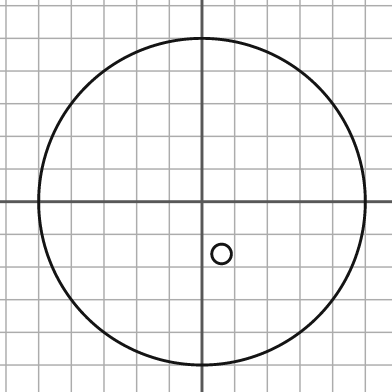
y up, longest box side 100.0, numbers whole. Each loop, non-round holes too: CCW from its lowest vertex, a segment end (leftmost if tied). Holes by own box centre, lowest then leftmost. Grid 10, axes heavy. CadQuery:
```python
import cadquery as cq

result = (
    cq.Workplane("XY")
    .moveTo(0.0, 0.0)
    .circle(50.0)
    .moveTo(6.0, -16.0)
    .circle(3.0)
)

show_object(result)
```